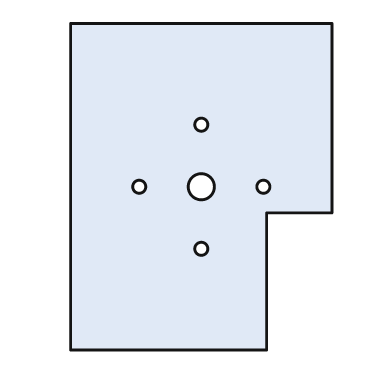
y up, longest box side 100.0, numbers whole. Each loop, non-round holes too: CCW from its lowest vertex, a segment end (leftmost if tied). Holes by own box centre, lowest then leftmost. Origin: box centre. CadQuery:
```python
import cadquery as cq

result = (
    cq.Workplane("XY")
    .moveTo(-40.0, -50.0)
    .lineTo(20.0, -50.0)
    .lineTo(20.0, -8.0)
    .lineTo(40.0, -8.0)
    .lineTo(40.0, 50.0)
    .lineTo(-40.0, 50.0)
    .close()
    .moveTo(0.0, -19.0)
    .circle(2.0)
    .moveTo(-19.0, 0.0)
    .circle(2.0)
    .moveTo(0.0, 0.0)
    .circle(4.0)
    .moveTo(19.0, 0.0)
    .circle(2.0)
    .moveTo(0.0, 19.0)
    .circle(2.0)
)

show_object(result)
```